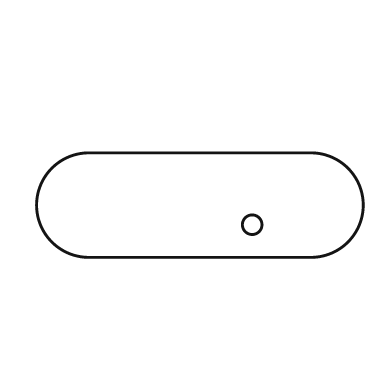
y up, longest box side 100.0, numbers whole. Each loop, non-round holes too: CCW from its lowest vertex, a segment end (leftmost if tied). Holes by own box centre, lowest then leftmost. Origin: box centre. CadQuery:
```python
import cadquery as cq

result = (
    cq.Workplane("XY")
    .moveTo(-34.0, -16.0)
    .lineTo(34.0, -16.0)
    .threePointArc((50.0, 0.0), (34.0, 16.0))
    .lineTo(-34.0, 16.0)
    .threePointArc((-50.0, 0.0), (-34.0, -16.0))
    .close()
    .moveTo(16.0, -6.0)
    .circle(3.0)
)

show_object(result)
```